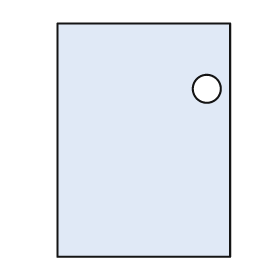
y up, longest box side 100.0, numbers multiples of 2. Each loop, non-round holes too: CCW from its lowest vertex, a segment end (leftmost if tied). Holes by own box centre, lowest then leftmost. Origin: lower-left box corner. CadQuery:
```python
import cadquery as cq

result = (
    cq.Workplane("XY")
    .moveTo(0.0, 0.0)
    .lineTo(74.0, 0.0)
    .lineTo(74.0, 100.0)
    .lineTo(0.0, 100.0)
    .close()
    .moveTo(64.0, 72.0)
    .circle(6.0)
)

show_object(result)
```